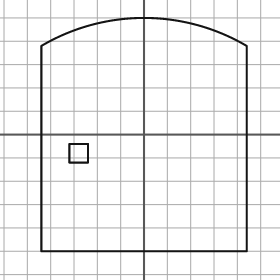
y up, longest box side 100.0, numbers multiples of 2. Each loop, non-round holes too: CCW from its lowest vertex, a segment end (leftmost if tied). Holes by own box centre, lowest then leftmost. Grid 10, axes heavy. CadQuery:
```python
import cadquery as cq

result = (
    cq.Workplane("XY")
    .moveTo(-44.0, -50.0)
    .lineTo(44.0, -50.0)
    .lineTo(44.0, 38.0)
    .threePointArc((0.0, 50.0), (-44.0, 38.0))
    .close()
    .moveTo(-32.0, -12.0)
    .lineTo(-24.0, -12.0)
    .lineTo(-24.0, -4.0)
    .lineTo(-32.0, -4.0)
    .close()
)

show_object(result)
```